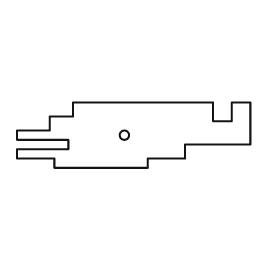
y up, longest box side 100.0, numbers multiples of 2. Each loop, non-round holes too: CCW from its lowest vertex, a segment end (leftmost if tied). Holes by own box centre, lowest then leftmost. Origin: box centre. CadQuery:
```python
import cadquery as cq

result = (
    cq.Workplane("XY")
    .moveTo(-34.0, -14.0)
    .lineTo(6.0, -14.0)
    .lineTo(6.0, -10.0)
    .lineTo(22.0, -10.0)
    .lineTo(22.0, -4.0)
    .lineTo(50.0, -4.0)
    .lineTo(50.0, 14.0)
    .lineTo(42.0, 14.0)
    .lineTo(42.0, 6.0)
    .lineTo(34.0, 6.0)
    .lineTo(34.0, 14.0)
    .lineTo(-26.0, 14.0)
    .lineTo(-26.0, 8.0)
    .lineTo(-36.0, 8.0)
    .lineTo(-36.0, 2.0)
    .lineTo(-50.0, 2.0)
    .lineTo(-50.0, -2.0)
    .lineTo(-28.0, -2.0)
    .lineTo(-28.0, -6.0)
    .lineTo(-50.0, -6.0)
    .lineTo(-50.0, -10.0)
    .lineTo(-34.0, -10.0)
    .close()
    .moveTo(-4.0, 0.0)
    .circle(2.0)
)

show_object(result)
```